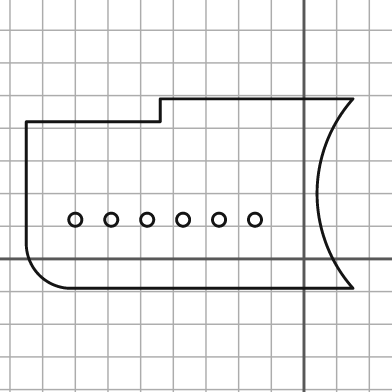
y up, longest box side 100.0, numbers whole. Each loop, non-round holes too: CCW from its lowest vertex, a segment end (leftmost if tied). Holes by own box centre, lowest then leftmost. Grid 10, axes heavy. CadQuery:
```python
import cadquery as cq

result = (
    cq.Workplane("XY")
    .moveTo(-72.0, -9.0)
    .lineTo(15.0, -9.0)
    .threePointArc((4.0, 20.0), (15.0, 49.0))
    .lineTo(-44.0, 49.0)
    .lineTo(-44.0, 42.0)
    .lineTo(-85.0, 42.0)
    .lineTo(-85.0, 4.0)
    .threePointArc((-81.0, -5.0), (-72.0, -9.0))
    .close()
    .moveTo(-70.0, 12.0)
    .circle(2.0)
    .moveTo(-59.0, 12.0)
    .circle(2.0)
    .moveTo(-48.0, 12.0)
    .circle(2.0)
    .moveTo(-37.0, 12.0)
    .circle(2.0)
    .moveTo(-26.0, 12.0)
    .circle(2.0)
    .moveTo(-15.0, 12.0)
    .circle(2.0)
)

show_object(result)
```